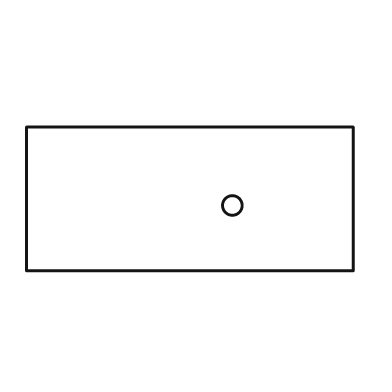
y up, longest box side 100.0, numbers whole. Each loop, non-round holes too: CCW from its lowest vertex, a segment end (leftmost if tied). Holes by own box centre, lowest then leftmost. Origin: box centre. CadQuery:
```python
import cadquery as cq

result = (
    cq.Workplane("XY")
    .moveTo(-50.0, -22.0)
    .lineTo(50.0, -22.0)
    .lineTo(50.0, 22.0)
    .lineTo(-50.0, 22.0)
    .close()
    .moveTo(13.0, -2.0)
    .circle(3.0)
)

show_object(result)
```